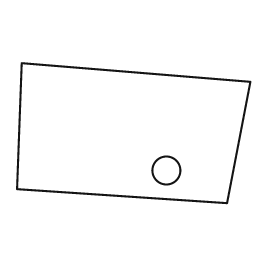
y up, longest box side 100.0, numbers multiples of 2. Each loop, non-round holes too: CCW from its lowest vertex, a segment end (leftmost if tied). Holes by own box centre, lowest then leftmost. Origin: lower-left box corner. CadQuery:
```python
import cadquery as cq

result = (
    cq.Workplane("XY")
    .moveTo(90.0, 0.0)
    .lineTo(100.0, 52.0)
    .lineTo(2.0, 60.0)
    .lineTo(0.0, 6.0)
    .close()
    .moveTo(64.0, 14.0)
    .circle(6.0)
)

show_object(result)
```